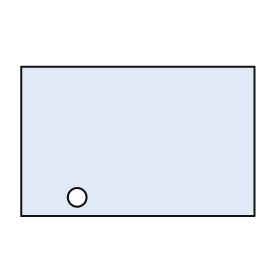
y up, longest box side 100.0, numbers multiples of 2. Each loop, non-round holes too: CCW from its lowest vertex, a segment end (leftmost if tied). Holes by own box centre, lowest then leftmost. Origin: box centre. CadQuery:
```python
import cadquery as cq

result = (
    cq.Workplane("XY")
    .moveTo(-50.0, -32.0)
    .lineTo(50.0, -32.0)
    .lineTo(50.0, 32.0)
    .lineTo(-50.0, 32.0)
    .close()
    .moveTo(-26.0, -24.0)
    .circle(4.0)
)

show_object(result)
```